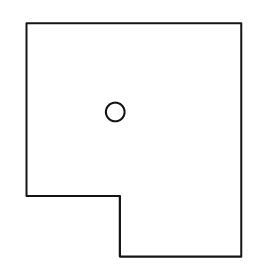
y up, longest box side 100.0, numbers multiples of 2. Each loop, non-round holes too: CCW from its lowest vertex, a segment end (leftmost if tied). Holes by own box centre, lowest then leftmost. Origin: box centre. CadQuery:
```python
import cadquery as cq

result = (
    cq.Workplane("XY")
    .moveTo(-6.0, -50.0)
    .lineTo(46.0, -50.0)
    .lineTo(46.0, 50.0)
    .lineTo(-46.0, 50.0)
    .lineTo(-46.0, -24.0)
    .lineTo(-6.0, -24.0)
    .close()
    .moveTo(-8.0, 12.0)
    .circle(4.0)
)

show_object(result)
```